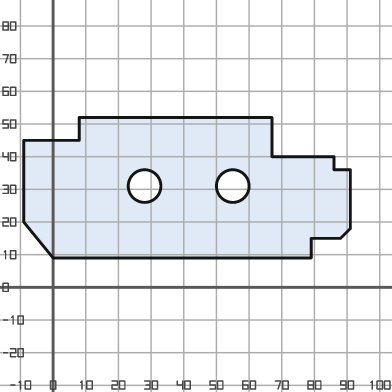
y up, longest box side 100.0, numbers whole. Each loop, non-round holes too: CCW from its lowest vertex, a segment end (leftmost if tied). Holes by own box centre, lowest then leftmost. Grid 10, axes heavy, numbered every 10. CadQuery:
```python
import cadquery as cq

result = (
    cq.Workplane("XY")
    .moveTo(0.0, 9.0)
    .lineTo(79.0, 9.0)
    .lineTo(79.0, 15.0)
    .lineTo(88.0, 15.0)
    .lineTo(91.0, 18.0)
    .lineTo(91.0, 36.0)
    .lineTo(86.0, 36.0)
    .lineTo(86.0, 40.0)
    .lineTo(67.0, 40.0)
    .lineTo(67.0, 52.0)
    .lineTo(8.0, 52.0)
    .lineTo(8.0, 45.0)
    .lineTo(-9.0, 45.0)
    .lineTo(-9.0, 20.0)
    .close()
    .moveTo(28.0, 31.0)
    .circle(5.0)
    .moveTo(55.0, 31.0)
    .circle(5.0)
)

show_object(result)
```